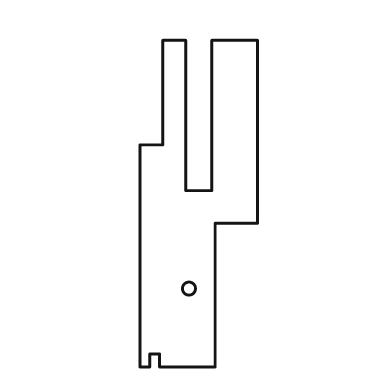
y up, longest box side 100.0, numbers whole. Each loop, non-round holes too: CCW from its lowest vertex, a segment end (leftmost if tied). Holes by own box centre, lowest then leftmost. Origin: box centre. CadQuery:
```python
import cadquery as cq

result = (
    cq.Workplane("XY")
    .moveTo(-18.0, -50.0)
    .lineTo(-15.0, -50.0)
    .lineTo(-15.0, -46.0)
    .lineTo(-12.0, -46.0)
    .lineTo(-12.0, -50.0)
    .lineTo(5.0, -50.0)
    .lineTo(5.0, -6.0)
    .lineTo(18.0, -6.0)
    .lineTo(18.0, 50.0)
    .lineTo(4.0, 50.0)
    .lineTo(4.0, 4.0)
    .lineTo(-4.0, 4.0)
    .lineTo(-4.0, 50.0)
    .lineTo(-11.0, 50.0)
    .lineTo(-11.0, 18.0)
    .lineTo(-18.0, 18.0)
    .close()
    .moveTo(-3.0, -26.0)
    .circle(2.0)
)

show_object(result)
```